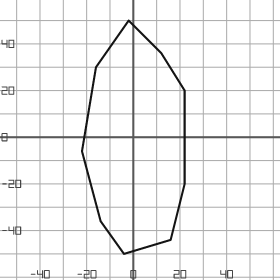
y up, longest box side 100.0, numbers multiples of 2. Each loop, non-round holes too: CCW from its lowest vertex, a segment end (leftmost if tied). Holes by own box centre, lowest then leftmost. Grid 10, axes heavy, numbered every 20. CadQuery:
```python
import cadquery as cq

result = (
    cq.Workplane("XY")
    .moveTo(-4.0, -50.0)
    .lineTo(16.0, -44.0)
    .lineTo(22.0, -20.0)
    .lineTo(22.0, 20.0)
    .lineTo(12.0, 36.0)
    .lineTo(-2.0, 50.0)
    .lineTo(-16.0, 30.0)
    .lineTo(-22.0, -6.0)
    .lineTo(-14.0, -36.0)
    .close()
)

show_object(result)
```